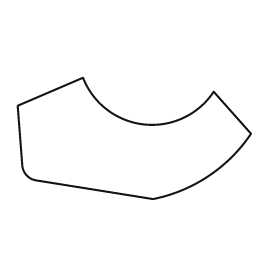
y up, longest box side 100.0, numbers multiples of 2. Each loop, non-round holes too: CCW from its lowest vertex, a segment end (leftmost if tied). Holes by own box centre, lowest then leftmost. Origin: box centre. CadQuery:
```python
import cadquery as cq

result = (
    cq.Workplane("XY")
    .moveTo(8.0, -26.0)
    .threePointArc((32.0, -16.0), (50.0, 2.0))
    .lineTo(34.0, 20.0)
    .threePointArc((4.0, 6.0), (-22.0, 26.0))
    .lineTo(-50.0, 14.0)
    .lineTo(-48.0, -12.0)
    .threePointArc((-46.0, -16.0), (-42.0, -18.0))
    .close()
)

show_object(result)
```